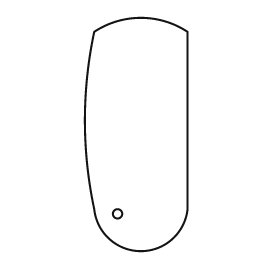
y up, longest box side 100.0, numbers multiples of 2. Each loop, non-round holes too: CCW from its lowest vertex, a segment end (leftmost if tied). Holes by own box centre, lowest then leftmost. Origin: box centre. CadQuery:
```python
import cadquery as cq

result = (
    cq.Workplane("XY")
    .moveTo(-18.0, -32.0)
    .threePointArc((2.0, -50.0), (22.0, -32.0))
    .lineTo(22.0, 44.0)
    .threePointArc((2.0, 50.0), (-18.0, 44.0))
    .threePointArc((-22.0, 6.0), (-18.0, -32.0))
    .close()
    .moveTo(-8.0, -34.0)
    .circle(2.0)
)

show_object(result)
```